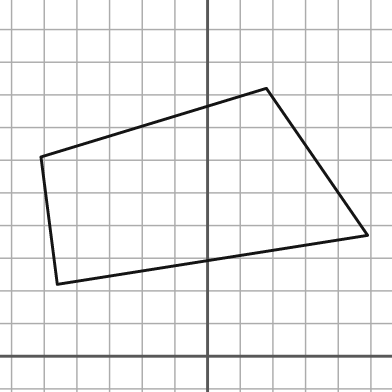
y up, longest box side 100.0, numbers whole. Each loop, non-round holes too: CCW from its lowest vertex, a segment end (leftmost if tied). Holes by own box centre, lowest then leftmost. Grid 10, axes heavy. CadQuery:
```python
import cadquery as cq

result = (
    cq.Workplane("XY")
    .moveTo(-46.0, 22.0)
    .lineTo(49.0, 37.0)
    .lineTo(18.0, 82.0)
    .lineTo(-51.0, 61.0)
    .close()
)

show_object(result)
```